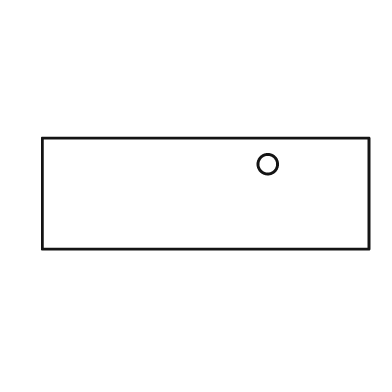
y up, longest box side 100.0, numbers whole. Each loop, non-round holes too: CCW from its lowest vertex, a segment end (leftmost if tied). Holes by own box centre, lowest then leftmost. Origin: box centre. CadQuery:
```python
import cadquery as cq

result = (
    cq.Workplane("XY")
    .moveTo(-50.0, -17.0)
    .lineTo(50.0, -17.0)
    .lineTo(50.0, 17.0)
    .lineTo(-50.0, 17.0)
    .close()
    .moveTo(19.0, 9.0)
    .circle(3.0)
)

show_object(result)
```